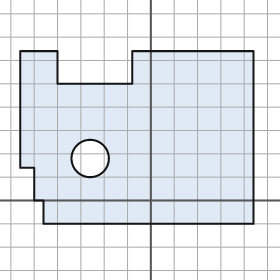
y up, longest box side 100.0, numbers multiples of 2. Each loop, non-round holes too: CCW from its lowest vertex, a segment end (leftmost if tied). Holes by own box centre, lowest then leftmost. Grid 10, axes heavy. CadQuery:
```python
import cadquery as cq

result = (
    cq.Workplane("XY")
    .moveTo(-46.0, -10.0)
    .lineTo(44.0, -10.0)
    .lineTo(44.0, 64.0)
    .lineTo(-8.0, 64.0)
    .lineTo(-8.0, 50.0)
    .lineTo(-40.0, 50.0)
    .lineTo(-40.0, 64.0)
    .lineTo(-56.0, 64.0)
    .lineTo(-56.0, 14.0)
    .lineTo(-50.0, 14.0)
    .lineTo(-50.0, 0.0)
    .lineTo(-46.0, 0.0)
    .close()
    .moveTo(-26.0, 18.0)
    .circle(8.0)
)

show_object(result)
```